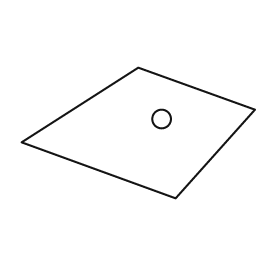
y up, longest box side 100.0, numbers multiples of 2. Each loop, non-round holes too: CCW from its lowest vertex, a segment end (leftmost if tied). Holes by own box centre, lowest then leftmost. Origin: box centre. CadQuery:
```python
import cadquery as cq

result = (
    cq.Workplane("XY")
    .moveTo(16.0, -28.0)
    .lineTo(50.0, 10.0)
    .lineTo(0.0, 28.0)
    .lineTo(-50.0, -4.0)
    .close()
    .moveTo(10.0, 6.0)
    .circle(4.0)
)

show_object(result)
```